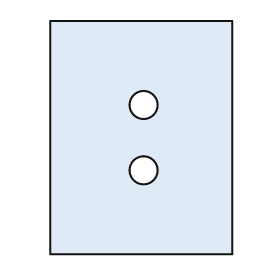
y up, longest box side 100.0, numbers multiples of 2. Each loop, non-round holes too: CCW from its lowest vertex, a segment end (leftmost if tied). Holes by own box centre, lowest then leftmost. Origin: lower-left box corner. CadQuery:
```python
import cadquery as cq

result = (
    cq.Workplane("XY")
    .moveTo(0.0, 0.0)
    .lineTo(78.0, 0.0)
    .lineTo(78.0, 100.0)
    .lineTo(0.0, 100.0)
    .close()
    .moveTo(40.0, 36.0)
    .circle(6.0)
    .moveTo(40.0, 64.0)
    .circle(6.0)
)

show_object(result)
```